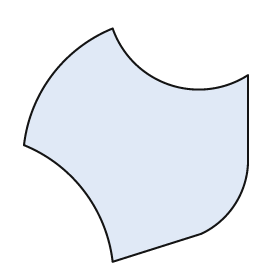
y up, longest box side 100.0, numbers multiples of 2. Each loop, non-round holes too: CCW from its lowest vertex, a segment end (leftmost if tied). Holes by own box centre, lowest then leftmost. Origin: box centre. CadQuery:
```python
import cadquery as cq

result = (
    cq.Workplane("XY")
    .moveTo(-10.0, -50.0)
    .lineTo(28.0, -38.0)
    .threePointArc((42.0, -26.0), (48.0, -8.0))
    .lineTo(48.0, 30.0)
    .threePointArc((14.0, 26.0), (-10.0, 50.0))
    .threePointArc((-36.0, 30.0), (-48.0, 0.0))
    .threePointArc((-22.0, -20.0), (-10.0, -50.0))
    .close()
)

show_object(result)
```